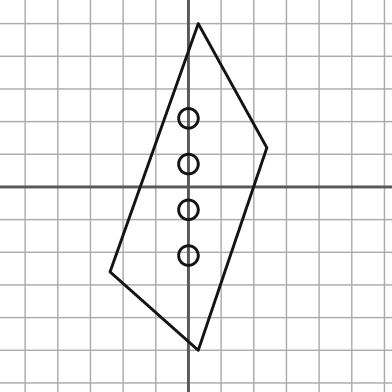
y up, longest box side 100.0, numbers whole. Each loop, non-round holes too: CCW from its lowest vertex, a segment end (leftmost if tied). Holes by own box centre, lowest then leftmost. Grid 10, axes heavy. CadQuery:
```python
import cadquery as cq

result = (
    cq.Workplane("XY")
    .moveTo(3.0, -50.0)
    .lineTo(24.0, 12.0)
    .lineTo(3.0, 50.0)
    .lineTo(-24.0, -26.0)
    .close()
    .moveTo(0.0, -21.0)
    .circle(3.0)
    .moveTo(0.0, -7.0)
    .circle(3.0)
    .moveTo(0.0, 7.0)
    .circle(3.0)
    .moveTo(0.0, 21.0)
    .circle(3.0)
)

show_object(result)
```